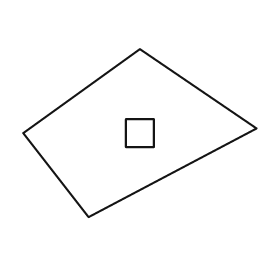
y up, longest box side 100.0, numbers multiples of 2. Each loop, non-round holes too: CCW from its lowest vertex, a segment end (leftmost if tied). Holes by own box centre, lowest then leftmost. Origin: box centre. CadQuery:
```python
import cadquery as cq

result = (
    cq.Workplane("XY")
    .moveTo(-22.0, -36.0)
    .lineTo(50.0, 2.0)
    .lineTo(0.0, 36.0)
    .lineTo(-50.0, 0.0)
    .close()
    .moveTo(-6.0, -6.0)
    .lineTo(6.0, -6.0)
    .lineTo(6.0, 6.0)
    .lineTo(-6.0, 6.0)
    .close()
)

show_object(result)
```